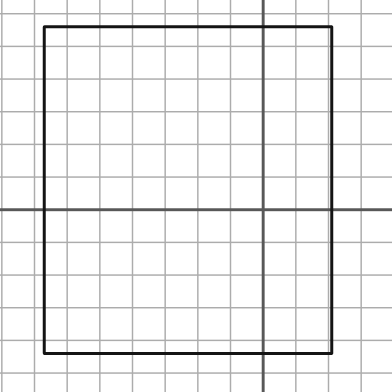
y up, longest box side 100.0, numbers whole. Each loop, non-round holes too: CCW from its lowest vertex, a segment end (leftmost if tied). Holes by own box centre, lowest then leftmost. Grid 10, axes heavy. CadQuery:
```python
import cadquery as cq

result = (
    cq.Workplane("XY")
    .moveTo(-67.0, -44.0)
    .lineTo(21.0, -44.0)
    .lineTo(21.0, 56.0)
    .lineTo(-67.0, 56.0)
    .close()
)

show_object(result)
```